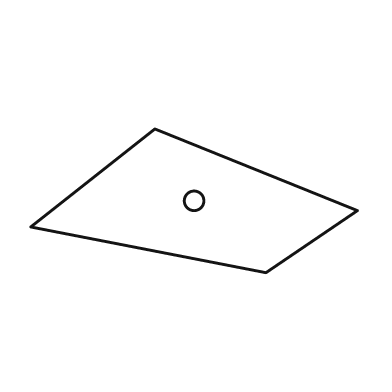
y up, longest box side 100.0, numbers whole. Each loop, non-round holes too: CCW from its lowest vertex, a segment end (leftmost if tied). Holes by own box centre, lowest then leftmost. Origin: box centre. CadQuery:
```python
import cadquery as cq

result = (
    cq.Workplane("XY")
    .moveTo(22.0, -22.0)
    .lineTo(50.0, -3.0)
    .lineTo(-12.0, 22.0)
    .lineTo(-50.0, -8.0)
    .close()
    .moveTo(0.0, 0.0)
    .circle(3.0)
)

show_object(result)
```